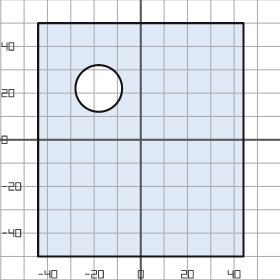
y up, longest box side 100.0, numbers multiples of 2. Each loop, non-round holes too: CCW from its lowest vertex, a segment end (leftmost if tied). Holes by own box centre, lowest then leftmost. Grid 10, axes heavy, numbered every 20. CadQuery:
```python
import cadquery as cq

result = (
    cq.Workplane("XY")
    .moveTo(-44.0, -50.0)
    .lineTo(44.0, -50.0)
    .lineTo(44.0, 50.0)
    .lineTo(-44.0, 50.0)
    .close()
    .moveTo(-18.0, 22.0)
    .circle(10.0)
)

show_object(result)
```